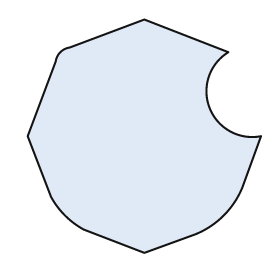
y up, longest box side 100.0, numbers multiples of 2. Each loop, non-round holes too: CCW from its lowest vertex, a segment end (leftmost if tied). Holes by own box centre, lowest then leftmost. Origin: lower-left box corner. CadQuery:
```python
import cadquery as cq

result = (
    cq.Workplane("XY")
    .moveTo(50.0, 0.0)
    .lineTo(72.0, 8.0)
    .threePointArc((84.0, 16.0), (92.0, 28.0))
    .lineTo(100.0, 50.0)
    .threePointArc((78.0, 62.0), (86.0, 86.0))
    .lineTo(50.0, 100.0)
    .lineTo(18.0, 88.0)
    .threePointArc((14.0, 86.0), (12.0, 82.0))
    .lineTo(0.0, 50.0)
    .lineTo(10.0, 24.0)
    .threePointArc((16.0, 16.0), (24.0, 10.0))
    .close()
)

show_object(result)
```